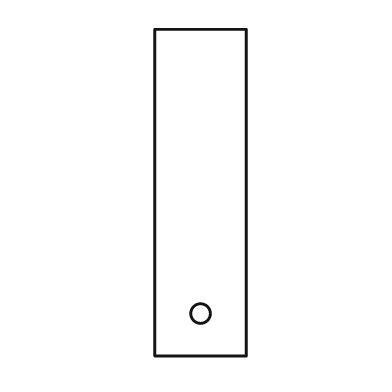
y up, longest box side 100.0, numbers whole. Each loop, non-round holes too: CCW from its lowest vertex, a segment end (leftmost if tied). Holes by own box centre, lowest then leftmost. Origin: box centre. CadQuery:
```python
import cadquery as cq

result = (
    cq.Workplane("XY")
    .moveTo(-14.0, -50.0)
    .lineTo(14.0, -50.0)
    .lineTo(14.0, 50.0)
    .lineTo(-14.0, 50.0)
    .close()
    .moveTo(0.0, -37.0)
    .circle(3.0)
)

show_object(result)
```